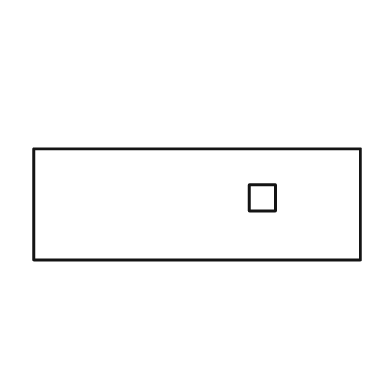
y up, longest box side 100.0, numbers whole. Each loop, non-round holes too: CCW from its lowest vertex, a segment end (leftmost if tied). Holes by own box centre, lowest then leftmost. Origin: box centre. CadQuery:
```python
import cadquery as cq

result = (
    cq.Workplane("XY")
    .moveTo(-50.0, -17.0)
    .lineTo(50.0, -17.0)
    .lineTo(50.0, 17.0)
    .lineTo(-50.0, 17.0)
    .close()
    .moveTo(16.0, -2.0)
    .lineTo(24.0, -2.0)
    .lineTo(24.0, 6.0)
    .lineTo(16.0, 6.0)
    .close()
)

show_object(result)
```